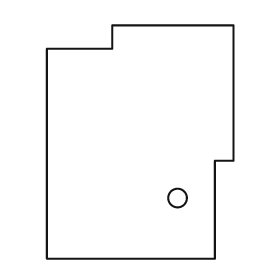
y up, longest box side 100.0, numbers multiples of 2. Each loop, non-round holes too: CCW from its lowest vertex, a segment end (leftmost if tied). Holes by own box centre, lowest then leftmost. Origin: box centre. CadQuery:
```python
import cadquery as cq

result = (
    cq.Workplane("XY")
    .moveTo(-40.0, -50.0)
    .lineTo(32.0, -50.0)
    .lineTo(32.0, -8.0)
    .lineTo(40.0, -8.0)
    .lineTo(40.0, 50.0)
    .lineTo(-12.0, 50.0)
    .lineTo(-12.0, 40.0)
    .lineTo(-40.0, 40.0)
    .close()
    .moveTo(16.0, -24.0)
    .circle(4.0)
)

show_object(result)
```